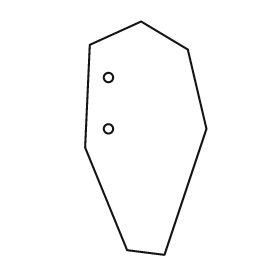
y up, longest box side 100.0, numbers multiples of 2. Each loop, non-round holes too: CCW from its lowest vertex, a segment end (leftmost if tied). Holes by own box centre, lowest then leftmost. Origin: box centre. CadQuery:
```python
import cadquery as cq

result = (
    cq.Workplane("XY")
    .moveTo(8.0, -50.0)
    .lineTo(26.0, 4.0)
    .lineTo(18.0, 38.0)
    .lineTo(-2.0, 50.0)
    .lineTo(-24.0, 40.0)
    .lineTo(-26.0, -4.0)
    .lineTo(-8.0, -48.0)
    .close()
    .moveTo(-16.0, 4.0)
    .circle(2.0)
    .moveTo(-16.0, 26.0)
    .circle(2.0)
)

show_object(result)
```